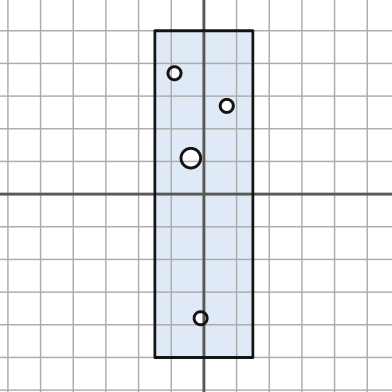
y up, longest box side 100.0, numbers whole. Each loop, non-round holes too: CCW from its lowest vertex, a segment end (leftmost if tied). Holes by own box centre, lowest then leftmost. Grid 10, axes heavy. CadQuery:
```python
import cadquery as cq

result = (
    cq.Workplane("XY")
    .moveTo(-15.0, -50.0)
    .lineTo(15.0, -50.0)
    .lineTo(15.0, 50.0)
    .lineTo(-15.0, 50.0)
    .close()
    .moveTo(-1.0, -38.0)
    .circle(2.0)
    .moveTo(-4.0, 11.0)
    .circle(3.0)
    .moveTo(7.0, 27.0)
    .circle(2.0)
    .moveTo(-9.0, 37.0)
    .circle(2.0)
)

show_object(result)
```